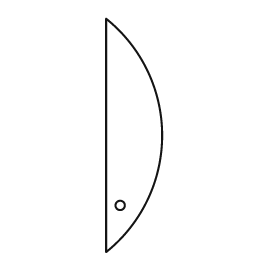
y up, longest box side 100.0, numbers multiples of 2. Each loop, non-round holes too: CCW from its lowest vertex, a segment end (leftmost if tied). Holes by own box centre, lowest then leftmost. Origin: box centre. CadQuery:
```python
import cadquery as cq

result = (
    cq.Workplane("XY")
    .moveTo(-12.0, -50.0)
    .threePointArc((12.0, 0.0), (-12.0, 50.0))
    .close()
    .moveTo(-6.0, -30.0)
    .circle(2.0)
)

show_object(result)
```